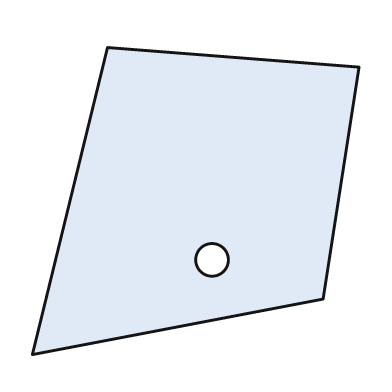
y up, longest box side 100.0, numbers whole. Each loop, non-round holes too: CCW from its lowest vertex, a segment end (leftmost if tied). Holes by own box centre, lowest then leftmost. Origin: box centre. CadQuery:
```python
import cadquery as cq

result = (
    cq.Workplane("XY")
    .moveTo(-50.0, -47.0)
    .lineTo(39.0, -30.0)
    .lineTo(50.0, 41.0)
    .lineTo(-27.0, 47.0)
    .close()
    .moveTo(5.0, -18.0)
    .circle(5.0)
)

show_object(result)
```